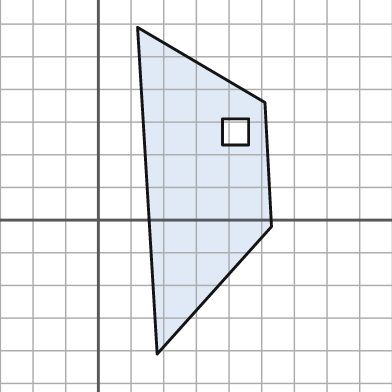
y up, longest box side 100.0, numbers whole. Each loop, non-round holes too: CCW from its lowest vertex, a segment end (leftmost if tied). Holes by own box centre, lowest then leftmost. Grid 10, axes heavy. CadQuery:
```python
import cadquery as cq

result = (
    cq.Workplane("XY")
    .moveTo(18.0, -41.0)
    .lineTo(53.0, -2.0)
    .lineTo(51.0, 36.0)
    .lineTo(12.0, 59.0)
    .close()
    .moveTo(38.0, 23.0)
    .lineTo(46.0, 23.0)
    .lineTo(46.0, 31.0)
    .lineTo(38.0, 31.0)
    .close()
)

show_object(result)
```